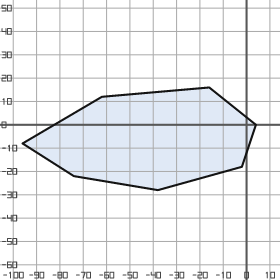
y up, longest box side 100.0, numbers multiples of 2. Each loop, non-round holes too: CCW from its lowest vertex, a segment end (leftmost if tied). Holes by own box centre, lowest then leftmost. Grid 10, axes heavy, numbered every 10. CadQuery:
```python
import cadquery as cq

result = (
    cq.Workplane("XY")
    .moveTo(-38.0, -28.0)
    .lineTo(-2.0, -18.0)
    .lineTo(4.0, 0.0)
    .lineTo(-16.0, 16.0)
    .lineTo(-62.0, 12.0)
    .lineTo(-96.0, -8.0)
    .lineTo(-74.0, -22.0)
    .close()
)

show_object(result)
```